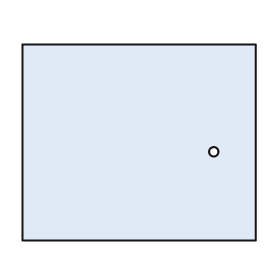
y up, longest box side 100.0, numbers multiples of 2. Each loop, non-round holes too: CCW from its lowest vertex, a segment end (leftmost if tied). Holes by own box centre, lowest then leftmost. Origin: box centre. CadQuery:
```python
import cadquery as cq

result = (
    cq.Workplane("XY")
    .moveTo(-50.0, -42.0)
    .lineTo(50.0, -42.0)
    .lineTo(50.0, 42.0)
    .lineTo(-50.0, 42.0)
    .close()
    .moveTo(32.0, -4.0)
    .circle(2.0)
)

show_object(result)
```